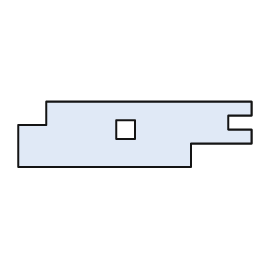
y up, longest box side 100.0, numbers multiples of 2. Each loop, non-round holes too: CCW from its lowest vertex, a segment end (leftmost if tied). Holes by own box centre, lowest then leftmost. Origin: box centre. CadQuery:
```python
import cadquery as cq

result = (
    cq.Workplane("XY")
    .moveTo(-50.0, -14.0)
    .lineTo(24.0, -14.0)
    .lineTo(24.0, -4.0)
    .lineTo(50.0, -4.0)
    .lineTo(50.0, 2.0)
    .lineTo(40.0, 2.0)
    .lineTo(40.0, 8.0)
    .lineTo(50.0, 8.0)
    .lineTo(50.0, 14.0)
    .lineTo(-38.0, 14.0)
    .lineTo(-38.0, 4.0)
    .lineTo(-50.0, 4.0)
    .close()
    .moveTo(-8.0, -2.0)
    .lineTo(0.0, -2.0)
    .lineTo(0.0, 6.0)
    .lineTo(-8.0, 6.0)
    .close()
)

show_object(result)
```